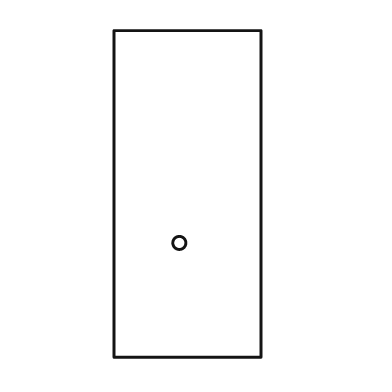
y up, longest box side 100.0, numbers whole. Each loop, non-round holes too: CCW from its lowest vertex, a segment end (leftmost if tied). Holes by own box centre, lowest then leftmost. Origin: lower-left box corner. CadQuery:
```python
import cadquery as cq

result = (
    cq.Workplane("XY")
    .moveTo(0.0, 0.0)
    .lineTo(45.0, 0.0)
    .lineTo(45.0, 100.0)
    .lineTo(0.0, 100.0)
    .close()
    .moveTo(20.0, 35.0)
    .circle(2.0)
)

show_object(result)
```